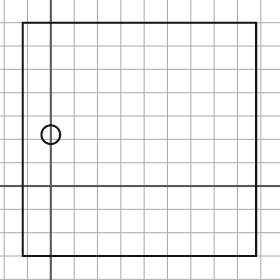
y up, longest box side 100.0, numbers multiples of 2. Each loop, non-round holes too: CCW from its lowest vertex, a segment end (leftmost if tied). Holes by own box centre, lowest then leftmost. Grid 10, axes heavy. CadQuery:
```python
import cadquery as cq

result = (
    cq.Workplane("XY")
    .moveTo(-12.0, -30.0)
    .lineTo(88.0, -30.0)
    .lineTo(88.0, 70.0)
    .lineTo(-12.0, 70.0)
    .close()
    .moveTo(0.0, 22.0)
    .circle(4.0)
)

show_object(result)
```